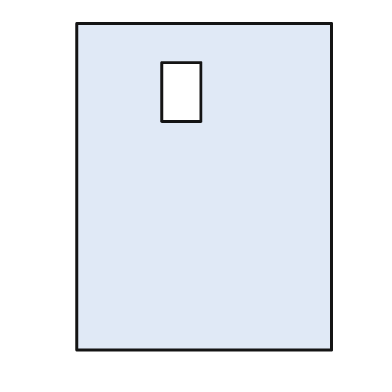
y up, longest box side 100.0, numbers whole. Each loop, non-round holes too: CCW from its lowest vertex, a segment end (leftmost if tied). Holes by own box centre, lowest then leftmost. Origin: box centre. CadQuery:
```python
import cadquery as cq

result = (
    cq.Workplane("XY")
    .moveTo(-39.0, -50.0)
    .lineTo(39.0, -50.0)
    .lineTo(39.0, 50.0)
    .lineTo(-39.0, 50.0)
    .close()
    .moveTo(-13.0, 20.0)
    .lineTo(-1.0, 20.0)
    .lineTo(-1.0, 38.0)
    .lineTo(-13.0, 38.0)
    .close()
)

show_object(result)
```